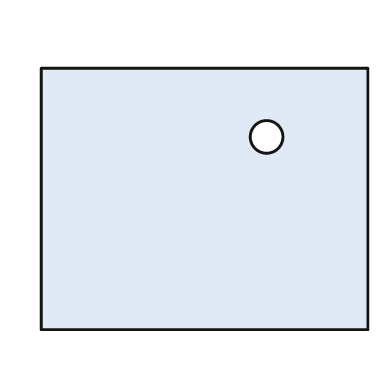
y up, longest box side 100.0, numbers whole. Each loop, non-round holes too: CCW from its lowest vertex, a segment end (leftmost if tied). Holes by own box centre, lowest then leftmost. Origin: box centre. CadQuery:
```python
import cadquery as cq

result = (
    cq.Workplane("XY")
    .moveTo(-50.0, -40.0)
    .lineTo(50.0, -40.0)
    .lineTo(50.0, 40.0)
    .lineTo(-50.0, 40.0)
    .close()
    .moveTo(19.0, 19.0)
    .circle(5.0)
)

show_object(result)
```